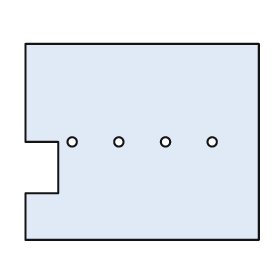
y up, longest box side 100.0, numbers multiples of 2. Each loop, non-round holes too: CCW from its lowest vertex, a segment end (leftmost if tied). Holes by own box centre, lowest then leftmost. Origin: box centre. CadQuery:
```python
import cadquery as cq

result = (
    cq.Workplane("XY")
    .moveTo(-50.0, -42.0)
    .lineTo(50.0, -42.0)
    .lineTo(50.0, 42.0)
    .lineTo(-50.0, 42.0)
    .lineTo(-50.0, 0.0)
    .lineTo(-36.0, 0.0)
    .lineTo(-36.0, -22.0)
    .lineTo(-50.0, -22.0)
    .close()
    .moveTo(-30.0, 0.0)
    .circle(2.0)
    .moveTo(-10.0, 0.0)
    .circle(2.0)
    .moveTo(10.0, 0.0)
    .circle(2.0)
    .moveTo(30.0, 0.0)
    .circle(2.0)
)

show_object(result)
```